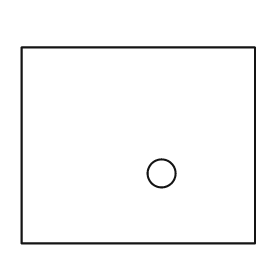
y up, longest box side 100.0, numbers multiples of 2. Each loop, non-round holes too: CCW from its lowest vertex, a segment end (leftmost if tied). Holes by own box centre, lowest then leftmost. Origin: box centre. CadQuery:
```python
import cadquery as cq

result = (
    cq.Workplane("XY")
    .moveTo(-50.0, -42.0)
    .lineTo(50.0, -42.0)
    .lineTo(50.0, 42.0)
    .lineTo(-50.0, 42.0)
    .close()
    .moveTo(10.0, -12.0)
    .circle(6.0)
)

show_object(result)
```